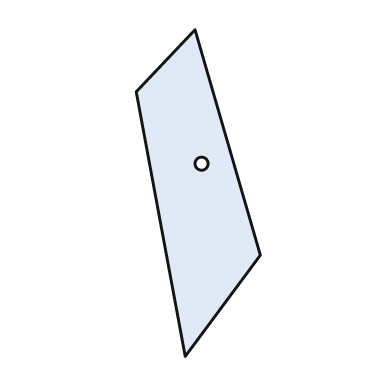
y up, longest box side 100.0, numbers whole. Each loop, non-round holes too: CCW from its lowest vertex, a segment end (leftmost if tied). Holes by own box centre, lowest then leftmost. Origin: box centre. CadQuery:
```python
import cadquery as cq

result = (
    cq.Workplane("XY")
    .moveTo(-4.0, -50.0)
    .lineTo(19.0, -19.0)
    .lineTo(-1.0, 50.0)
    .lineTo(-19.0, 31.0)
    .close()
    .moveTo(1.0, 9.0)
    .circle(2.0)
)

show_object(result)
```